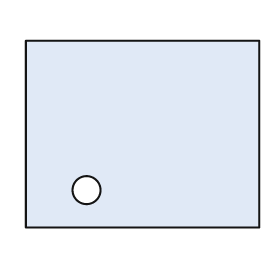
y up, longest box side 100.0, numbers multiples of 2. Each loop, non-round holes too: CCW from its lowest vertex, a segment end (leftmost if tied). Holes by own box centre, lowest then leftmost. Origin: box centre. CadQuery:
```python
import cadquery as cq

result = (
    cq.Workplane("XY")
    .moveTo(-50.0, -40.0)
    .lineTo(50.0, -40.0)
    .lineTo(50.0, 40.0)
    .lineTo(-50.0, 40.0)
    .close()
    .moveTo(-24.0, -24.0)
    .circle(6.0)
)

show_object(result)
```